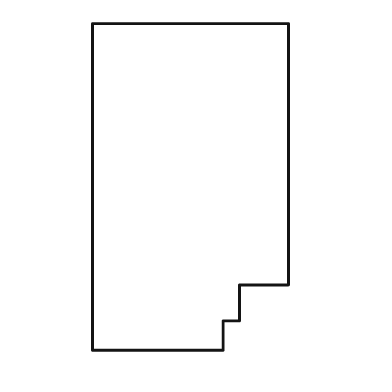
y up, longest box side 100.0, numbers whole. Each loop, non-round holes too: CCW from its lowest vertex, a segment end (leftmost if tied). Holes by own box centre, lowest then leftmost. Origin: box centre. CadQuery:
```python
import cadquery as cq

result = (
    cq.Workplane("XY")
    .moveTo(-30.0, -50.0)
    .lineTo(10.0, -50.0)
    .lineTo(10.0, -41.0)
    .lineTo(15.0, -41.0)
    .lineTo(15.0, -30.0)
    .lineTo(30.0, -30.0)
    .lineTo(30.0, 50.0)
    .lineTo(-30.0, 50.0)
    .close()
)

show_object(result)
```